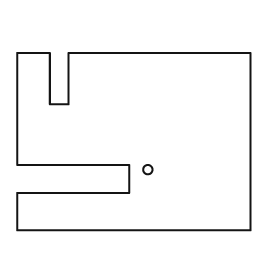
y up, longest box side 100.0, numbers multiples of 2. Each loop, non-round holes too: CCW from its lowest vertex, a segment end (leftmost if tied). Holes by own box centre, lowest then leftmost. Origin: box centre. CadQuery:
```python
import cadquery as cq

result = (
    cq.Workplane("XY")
    .moveTo(-50.0, -38.0)
    .lineTo(50.0, -38.0)
    .lineTo(50.0, 38.0)
    .lineTo(-28.0, 38.0)
    .lineTo(-28.0, 16.0)
    .lineTo(-36.0, 16.0)
    .lineTo(-36.0, 38.0)
    .lineTo(-50.0, 38.0)
    .lineTo(-50.0, -10.0)
    .lineTo(-2.0, -10.0)
    .lineTo(-2.0, -22.0)
    .lineTo(-50.0, -22.0)
    .close()
    .moveTo(6.0, -12.0)
    .circle(2.0)
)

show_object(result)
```